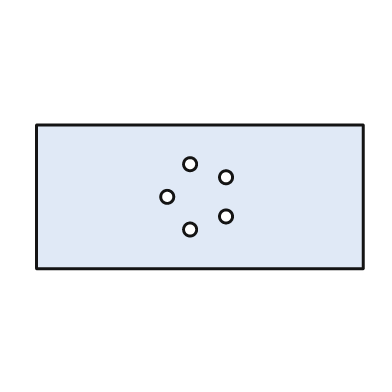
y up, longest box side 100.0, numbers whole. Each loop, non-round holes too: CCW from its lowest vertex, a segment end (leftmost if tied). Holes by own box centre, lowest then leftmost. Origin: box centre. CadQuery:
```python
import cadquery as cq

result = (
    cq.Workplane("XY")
    .moveTo(-50.0, -22.0)
    .lineTo(50.0, -22.0)
    .lineTo(50.0, 22.0)
    .lineTo(-50.0, 22.0)
    .close()
    .moveTo(-3.0, -10.0)
    .circle(2.0)
    .moveTo(8.0, -6.0)
    .circle(2.0)
    .moveTo(-10.0, 0.0)
    .circle(2.0)
    .moveTo(8.0, 6.0)
    .circle(2.0)
    .moveTo(-3.0, 10.0)
    .circle(2.0)
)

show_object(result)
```